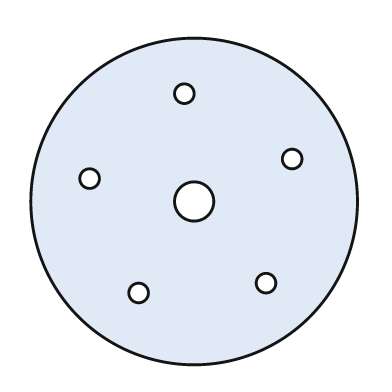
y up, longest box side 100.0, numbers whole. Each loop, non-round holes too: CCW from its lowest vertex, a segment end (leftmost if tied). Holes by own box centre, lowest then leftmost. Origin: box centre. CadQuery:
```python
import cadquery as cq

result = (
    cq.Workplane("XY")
    .moveTo(0.0, 0.0)
    .circle(50.0)
    .moveTo(-17.0, -28.0)
    .circle(3.0)
    .moveTo(22.0, -25.0)
    .circle(3.0)
    .moveTo(0.0, 0.0)
    .circle(6.0)
    .moveTo(-32.0, 7.0)
    .circle(3.0)
    .moveTo(30.0, 13.0)
    .circle(3.0)
    .moveTo(-3.0, 33.0)
    .circle(3.0)
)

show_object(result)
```